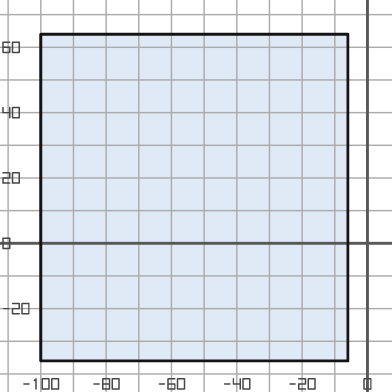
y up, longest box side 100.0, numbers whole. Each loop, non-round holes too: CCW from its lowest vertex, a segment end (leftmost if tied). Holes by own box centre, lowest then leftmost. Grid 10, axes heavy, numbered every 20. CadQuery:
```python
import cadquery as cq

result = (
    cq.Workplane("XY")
    .moveTo(-100.0, -36.0)
    .lineTo(-6.0, -36.0)
    .lineTo(-6.0, 64.0)
    .lineTo(-100.0, 64.0)
    .close()
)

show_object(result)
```